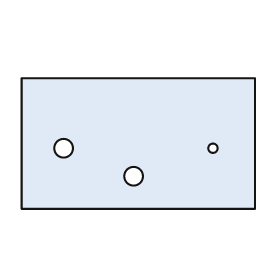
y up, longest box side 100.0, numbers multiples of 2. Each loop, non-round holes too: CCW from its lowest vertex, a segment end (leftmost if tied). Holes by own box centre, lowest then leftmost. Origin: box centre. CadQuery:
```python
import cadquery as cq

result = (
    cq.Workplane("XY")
    .moveTo(-50.0, -28.0)
    .lineTo(50.0, -28.0)
    .lineTo(50.0, 28.0)
    .lineTo(-50.0, 28.0)
    .close()
    .moveTo(-2.0, -14.0)
    .circle(4.0)
    .moveTo(-32.0, -2.0)
    .circle(4.0)
    .moveTo(32.0, -2.0)
    .circle(2.0)
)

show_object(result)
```